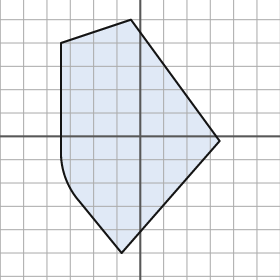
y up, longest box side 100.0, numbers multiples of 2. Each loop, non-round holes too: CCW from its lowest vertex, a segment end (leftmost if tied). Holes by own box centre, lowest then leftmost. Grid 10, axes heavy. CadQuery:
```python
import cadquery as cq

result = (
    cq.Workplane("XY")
    .moveTo(-8.0, -50.0)
    .lineTo(34.0, -2.0)
    .lineTo(-4.0, 50.0)
    .lineTo(-34.0, 40.0)
    .lineTo(-34.0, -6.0)
    .threePointArc((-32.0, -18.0), (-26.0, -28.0))
    .close()
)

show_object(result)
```